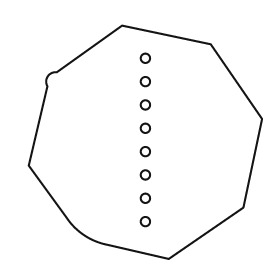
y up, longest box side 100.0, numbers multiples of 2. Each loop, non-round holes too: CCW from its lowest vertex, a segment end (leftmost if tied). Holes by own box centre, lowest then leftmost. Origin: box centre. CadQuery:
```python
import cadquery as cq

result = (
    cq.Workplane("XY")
    .moveTo(10.0, -50.0)
    .lineTo(42.0, -28.0)
    .lineTo(50.0, 10.0)
    .lineTo(28.0, 42.0)
    .lineTo(-10.0, 50.0)
    .lineTo(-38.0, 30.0)
    .threePointArc((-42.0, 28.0), (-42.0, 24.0))
    .lineTo(-50.0, -10.0)
    .lineTo(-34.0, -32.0)
    .threePointArc((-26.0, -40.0), (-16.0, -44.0))
    .close()
    .moveTo(0.0, -34.0)
    .circle(2.0)
    .moveTo(0.0, -24.0)
    .circle(2.0)
    .moveTo(0.0, -14.0)
    .circle(2.0)
    .moveTo(0.0, -4.0)
    .circle(2.0)
    .moveTo(0.0, 6.0)
    .circle(2.0)
    .moveTo(0.0, 16.0)
    .circle(2.0)
    .moveTo(0.0, 26.0)
    .circle(2.0)
    .moveTo(0.0, 36.0)
    .circle(2.0)
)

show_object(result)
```